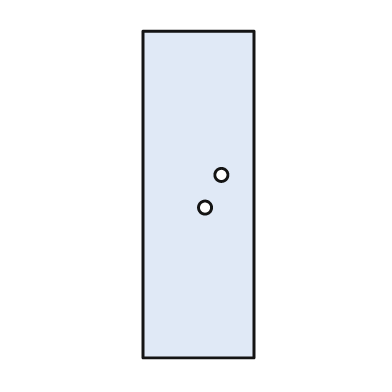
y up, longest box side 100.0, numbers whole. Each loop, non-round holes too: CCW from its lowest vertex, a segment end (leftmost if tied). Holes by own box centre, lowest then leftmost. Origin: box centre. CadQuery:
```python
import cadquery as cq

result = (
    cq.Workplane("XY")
    .moveTo(-17.0, -50.0)
    .lineTo(17.0, -50.0)
    .lineTo(17.0, 50.0)
    .lineTo(-17.0, 50.0)
    .close()
    .moveTo(2.0, -4.0)
    .circle(2.0)
    .moveTo(7.0, 6.0)
    .circle(2.0)
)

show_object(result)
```